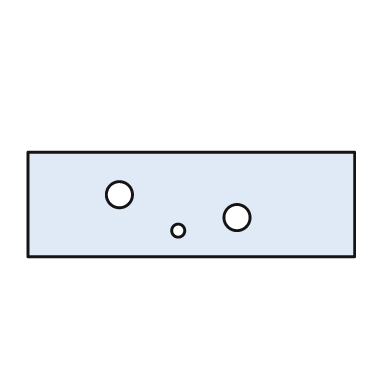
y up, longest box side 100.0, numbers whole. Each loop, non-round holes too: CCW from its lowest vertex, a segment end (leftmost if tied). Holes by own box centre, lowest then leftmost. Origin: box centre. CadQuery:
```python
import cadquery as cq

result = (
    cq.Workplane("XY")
    .moveTo(-50.0, -16.0)
    .lineTo(50.0, -16.0)
    .lineTo(50.0, 16.0)
    .lineTo(-50.0, 16.0)
    .close()
    .moveTo(-4.0, -8.0)
    .circle(2.0)
    .moveTo(14.0, -4.0)
    .circle(4.0)
    .moveTo(-22.0, 3.0)
    .circle(4.0)
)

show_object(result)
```